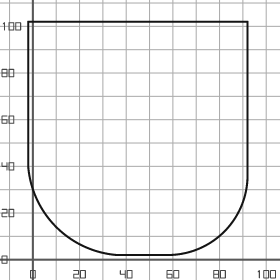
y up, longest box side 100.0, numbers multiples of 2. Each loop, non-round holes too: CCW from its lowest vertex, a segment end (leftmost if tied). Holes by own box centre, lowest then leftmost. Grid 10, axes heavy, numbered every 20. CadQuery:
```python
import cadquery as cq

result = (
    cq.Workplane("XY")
    .moveTo(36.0, 2.0)
    .lineTo(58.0, 2.0)
    .threePointArc((82.0, 12.0), (92.0, 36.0))
    .lineTo(92.0, 102.0)
    .lineTo(-2.0, 102.0)
    .lineTo(-2.0, 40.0)
    .threePointArc((10.0, 14.0), (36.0, 2.0))
    .close()
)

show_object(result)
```